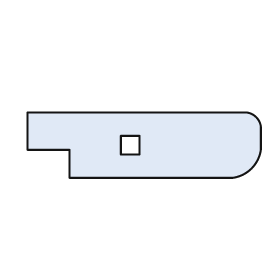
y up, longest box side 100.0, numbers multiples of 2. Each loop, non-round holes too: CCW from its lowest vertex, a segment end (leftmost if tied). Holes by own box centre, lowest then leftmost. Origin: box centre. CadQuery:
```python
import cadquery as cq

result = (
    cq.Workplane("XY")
    .moveTo(-32.0, -14.0)
    .lineTo(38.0, -14.0)
    .threePointArc((46.0, -10.0), (50.0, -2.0))
    .lineTo(50.0, 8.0)
    .threePointArc((48.0, 12.0), (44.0, 14.0))
    .lineTo(-50.0, 14.0)
    .lineTo(-50.0, -2.0)
    .lineTo(-32.0, -2.0)
    .close()
    .moveTo(-10.0, -4.0)
    .lineTo(-2.0, -4.0)
    .lineTo(-2.0, 4.0)
    .lineTo(-10.0, 4.0)
    .close()
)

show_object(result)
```